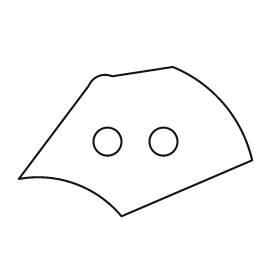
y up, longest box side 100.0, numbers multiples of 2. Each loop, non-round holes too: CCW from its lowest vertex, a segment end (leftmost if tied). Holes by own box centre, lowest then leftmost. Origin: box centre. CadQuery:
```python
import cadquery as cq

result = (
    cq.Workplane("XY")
    .moveTo(-6.0, -32.0)
    .lineTo(50.0, -8.0)
    .threePointArc((38.0, 16.0), (16.0, 32.0))
    .lineTo(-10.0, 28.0)
    .threePointArc((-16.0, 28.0), (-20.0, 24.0))
    .lineTo(-50.0, -16.0)
    .threePointArc((-26.0, -18.0), (-6.0, -32.0))
    .close()
    .moveTo(-12.0, 0.0)
    .circle(6.0)
    .moveTo(12.0, 0.0)
    .circle(6.0)
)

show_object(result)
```